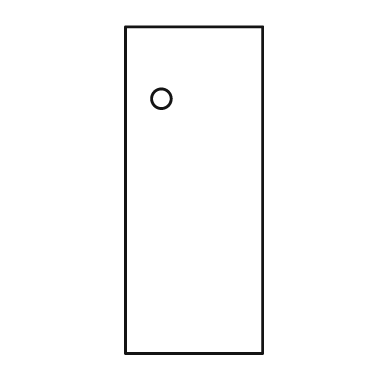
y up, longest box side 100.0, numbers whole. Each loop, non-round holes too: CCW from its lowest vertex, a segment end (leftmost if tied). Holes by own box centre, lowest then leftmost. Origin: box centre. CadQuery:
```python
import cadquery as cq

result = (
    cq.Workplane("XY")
    .moveTo(-21.0, -50.0)
    .lineTo(21.0, -50.0)
    .lineTo(21.0, 50.0)
    .lineTo(-21.0, 50.0)
    .close()
    .moveTo(-10.0, 28.0)
    .circle(3.0)
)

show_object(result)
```